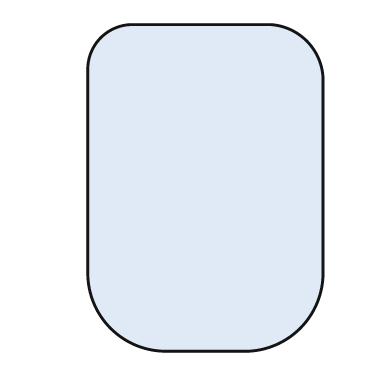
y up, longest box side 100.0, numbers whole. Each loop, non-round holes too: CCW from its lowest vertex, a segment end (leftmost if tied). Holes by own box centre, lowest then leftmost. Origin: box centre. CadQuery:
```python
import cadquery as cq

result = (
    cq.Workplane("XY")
    .moveTo(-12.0, -50.0)
    .lineTo(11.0, -50.0)
    .threePointArc((29.0, -43.0), (36.0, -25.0))
    .lineTo(36.0, 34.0)
    .threePointArc((31.0, 45.0), (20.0, 50.0))
    .lineTo(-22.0, 50.0)
    .threePointArc((-32.0, 46.0), (-36.0, 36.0))
    .lineTo(-36.0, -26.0)
    .threePointArc((-29.0, -43.0), (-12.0, -50.0))
    .close()
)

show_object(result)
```